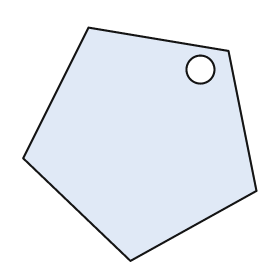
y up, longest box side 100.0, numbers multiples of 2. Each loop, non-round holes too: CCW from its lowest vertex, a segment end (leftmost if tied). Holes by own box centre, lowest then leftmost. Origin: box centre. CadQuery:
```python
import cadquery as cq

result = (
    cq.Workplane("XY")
    .moveTo(-4.0, -50.0)
    .lineTo(50.0, -20.0)
    .lineTo(38.0, 40.0)
    .lineTo(-22.0, 50.0)
    .lineTo(-50.0, -6.0)
    .close()
    .moveTo(26.0, 32.0)
    .circle(6.0)
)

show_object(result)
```